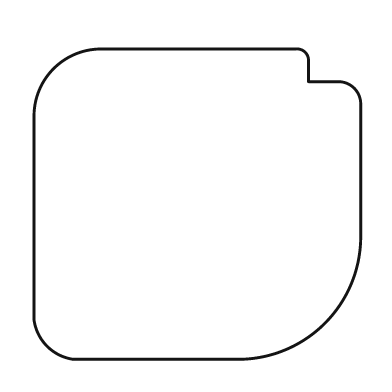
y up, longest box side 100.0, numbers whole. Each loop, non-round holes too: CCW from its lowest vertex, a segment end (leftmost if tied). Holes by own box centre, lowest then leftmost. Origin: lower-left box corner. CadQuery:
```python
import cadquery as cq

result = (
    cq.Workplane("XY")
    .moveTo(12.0, 0.0)
    .lineTo(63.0, 0.0)
    .threePointArc((89.0, 11.0), (100.0, 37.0))
    .lineTo(100.0, 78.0)
    .threePointArc((98.0, 83.0), (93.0, 85.0))
    .lineTo(84.0, 85.0)
    .lineTo(84.0, 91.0)
    .threePointArc((83.0, 94.0), (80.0, 95.0))
    .lineTo(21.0, 95.0)
    .threePointArc((6.0, 89.0), (0.0, 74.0))
    .lineTo(0.0, 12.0)
    .threePointArc((4.0, 4.0), (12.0, 0.0))
    .close()
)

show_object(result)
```